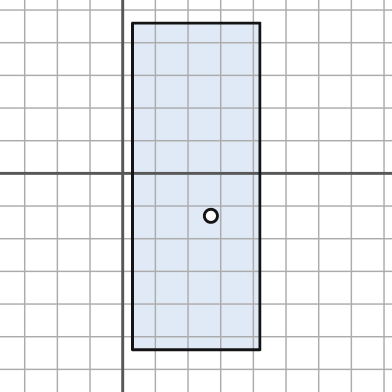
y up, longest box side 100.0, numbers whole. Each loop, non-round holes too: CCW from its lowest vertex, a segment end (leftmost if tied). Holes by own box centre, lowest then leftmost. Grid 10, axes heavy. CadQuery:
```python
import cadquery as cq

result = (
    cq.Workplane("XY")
    .moveTo(3.0, -54.0)
    .lineTo(42.0, -54.0)
    .lineTo(42.0, 46.0)
    .lineTo(3.0, 46.0)
    .close()
    .moveTo(27.0, -13.0)
    .circle(2.0)
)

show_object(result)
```